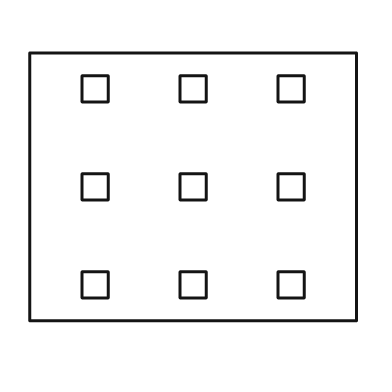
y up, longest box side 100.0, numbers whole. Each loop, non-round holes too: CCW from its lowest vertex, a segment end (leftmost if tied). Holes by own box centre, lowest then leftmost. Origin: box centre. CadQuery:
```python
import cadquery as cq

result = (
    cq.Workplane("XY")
    .moveTo(-50.0, -41.0)
    .lineTo(50.0, -41.0)
    .lineTo(50.0, 41.0)
    .lineTo(-50.0, 41.0)
    .close()
    .moveTo(-34.0, -34.0)
    .lineTo(-26.0, -34.0)
    .lineTo(-26.0, -26.0)
    .lineTo(-34.0, -26.0)
    .close()
    .moveTo(-4.0, -34.0)
    .lineTo(4.0, -34.0)
    .lineTo(4.0, -26.0)
    .lineTo(-4.0, -26.0)
    .close()
    .moveTo(26.0, -34.0)
    .lineTo(34.0, -34.0)
    .lineTo(34.0, -26.0)
    .lineTo(26.0, -26.0)
    .close()
    .moveTo(-34.0, -4.0)
    .lineTo(-26.0, -4.0)
    .lineTo(-26.0, 4.0)
    .lineTo(-34.0, 4.0)
    .close()
    .moveTo(-4.0, -4.0)
    .lineTo(4.0, -4.0)
    .lineTo(4.0, 4.0)
    .lineTo(-4.0, 4.0)
    .close()
    .moveTo(26.0, -4.0)
    .lineTo(34.0, -4.0)
    .lineTo(34.0, 4.0)
    .lineTo(26.0, 4.0)
    .close()
    .moveTo(-34.0, 26.0)
    .lineTo(-26.0, 26.0)
    .lineTo(-26.0, 34.0)
    .lineTo(-34.0, 34.0)
    .close()
    .moveTo(-4.0, 26.0)
    .lineTo(4.0, 26.0)
    .lineTo(4.0, 34.0)
    .lineTo(-4.0, 34.0)
    .close()
    .moveTo(26.0, 26.0)
    .lineTo(34.0, 26.0)
    .lineTo(34.0, 34.0)
    .lineTo(26.0, 34.0)
    .close()
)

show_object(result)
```